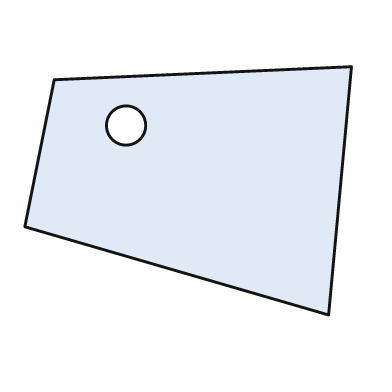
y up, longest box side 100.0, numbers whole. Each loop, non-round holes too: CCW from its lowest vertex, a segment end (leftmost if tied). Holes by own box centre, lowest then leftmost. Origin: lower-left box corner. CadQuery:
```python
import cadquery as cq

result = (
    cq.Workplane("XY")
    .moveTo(93.0, 0.0)
    .lineTo(100.0, 76.0)
    .lineTo(9.0, 72.0)
    .lineTo(0.0, 27.0)
    .close()
    .moveTo(31.0, 58.0)
    .circle(6.0)
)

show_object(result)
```